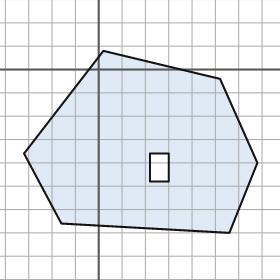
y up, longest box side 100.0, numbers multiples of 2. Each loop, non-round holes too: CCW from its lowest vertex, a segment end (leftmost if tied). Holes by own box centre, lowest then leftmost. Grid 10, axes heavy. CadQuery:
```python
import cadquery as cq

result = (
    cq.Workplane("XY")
    .moveTo(56.0, -70.0)
    .lineTo(68.0, -40.0)
    .lineTo(52.0, -4.0)
    .lineTo(2.0, 8.0)
    .lineTo(-32.0, -36.0)
    .lineTo(-16.0, -66.0)
    .close()
    .moveTo(22.0, -48.0)
    .lineTo(30.0, -48.0)
    .lineTo(30.0, -36.0)
    .lineTo(22.0, -36.0)
    .close()
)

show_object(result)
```